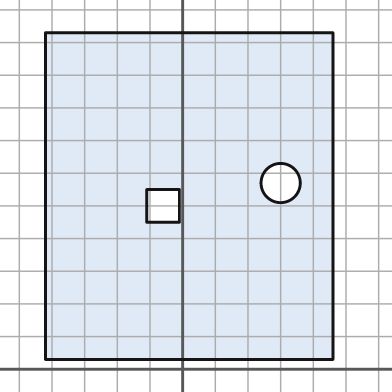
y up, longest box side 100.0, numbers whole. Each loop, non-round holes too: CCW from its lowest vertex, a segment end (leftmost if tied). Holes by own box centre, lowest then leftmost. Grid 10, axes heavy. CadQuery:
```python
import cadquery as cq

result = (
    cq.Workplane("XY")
    .moveTo(-42.0, 3.0)
    .lineTo(46.0, 3.0)
    .lineTo(46.0, 103.0)
    .lineTo(-42.0, 103.0)
    .close()
    .moveTo(-11.0, 45.0)
    .lineTo(-1.0, 45.0)
    .lineTo(-1.0, 55.0)
    .lineTo(-11.0, 55.0)
    .close()
    .moveTo(30.0, 57.0)
    .circle(6.0)
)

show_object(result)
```